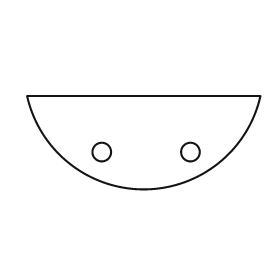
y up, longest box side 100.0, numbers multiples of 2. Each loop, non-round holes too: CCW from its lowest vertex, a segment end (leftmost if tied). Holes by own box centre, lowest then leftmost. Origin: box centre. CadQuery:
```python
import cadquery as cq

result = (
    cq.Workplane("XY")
    .moveTo(-50.0, 20.0)
    .threePointArc((0.0, -20.0), (50.0, 20.0))
    .close()
    .moveTo(-18.0, -4.0)
    .circle(4.0)
    .moveTo(20.0, -4.0)
    .circle(4.0)
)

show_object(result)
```